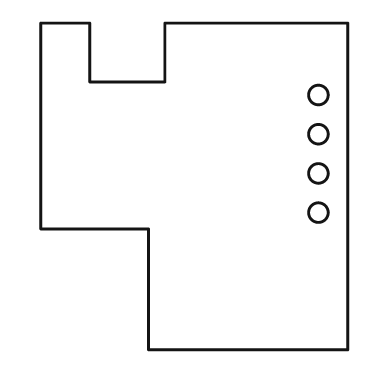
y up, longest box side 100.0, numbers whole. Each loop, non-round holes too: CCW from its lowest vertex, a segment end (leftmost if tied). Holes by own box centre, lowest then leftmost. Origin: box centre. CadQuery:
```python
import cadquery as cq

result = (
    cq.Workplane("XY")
    .moveTo(-14.0, -50.0)
    .lineTo(47.0, -50.0)
    .lineTo(47.0, 50.0)
    .lineTo(-9.0, 50.0)
    .lineTo(-9.0, 32.0)
    .lineTo(-32.0, 32.0)
    .lineTo(-32.0, 50.0)
    .lineTo(-47.0, 50.0)
    .lineTo(-47.0, -13.0)
    .lineTo(-14.0, -13.0)
    .close()
    .moveTo(38.0, -8.0)
    .circle(3.0)
    .moveTo(38.0, 4.0)
    .circle(3.0)
    .moveTo(38.0, 16.0)
    .circle(3.0)
    .moveTo(38.0, 28.0)
    .circle(3.0)
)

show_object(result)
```